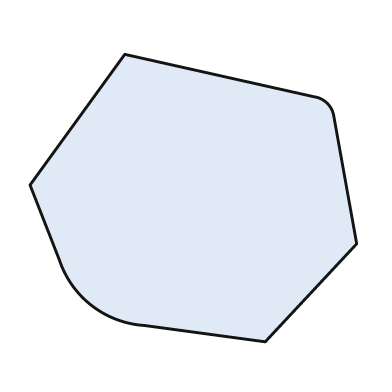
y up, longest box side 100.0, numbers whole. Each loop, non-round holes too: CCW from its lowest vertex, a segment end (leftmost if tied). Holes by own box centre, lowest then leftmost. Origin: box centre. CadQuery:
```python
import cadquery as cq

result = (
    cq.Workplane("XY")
    .moveTo(22.0, -44.0)
    .lineTo(50.0, -14.0)
    .lineTo(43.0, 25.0)
    .threePointArc((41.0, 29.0), (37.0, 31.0))
    .lineTo(-21.0, 44.0)
    .lineTo(-50.0, 4.0)
    .lineTo(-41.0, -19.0)
    .threePointArc((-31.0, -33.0), (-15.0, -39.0))
    .close()
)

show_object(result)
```